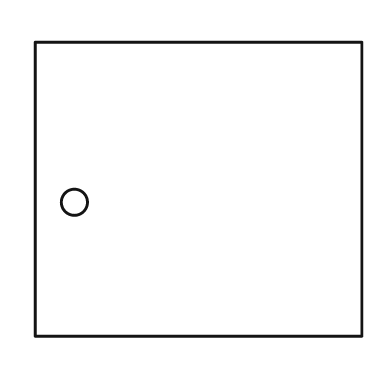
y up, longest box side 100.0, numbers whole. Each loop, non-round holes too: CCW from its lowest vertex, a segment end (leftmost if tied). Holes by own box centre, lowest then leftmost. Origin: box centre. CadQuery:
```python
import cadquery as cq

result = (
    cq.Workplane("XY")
    .moveTo(-50.0, -45.0)
    .lineTo(50.0, -45.0)
    .lineTo(50.0, 45.0)
    .lineTo(-50.0, 45.0)
    .close()
    .moveTo(-38.0, -4.0)
    .circle(4.0)
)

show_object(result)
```